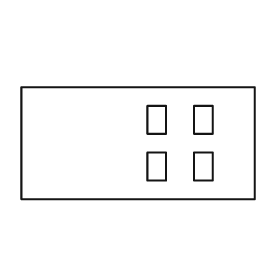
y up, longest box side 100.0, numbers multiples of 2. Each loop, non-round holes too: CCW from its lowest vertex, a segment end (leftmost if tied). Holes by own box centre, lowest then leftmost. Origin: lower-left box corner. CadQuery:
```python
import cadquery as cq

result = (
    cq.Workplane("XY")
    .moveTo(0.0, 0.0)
    .lineTo(100.0, 0.0)
    .lineTo(100.0, 48.0)
    .lineTo(0.0, 48.0)
    .close()
    .moveTo(54.0, 8.0)
    .lineTo(62.0, 8.0)
    .lineTo(62.0, 20.0)
    .lineTo(54.0, 20.0)
    .close()
    .moveTo(74.0, 8.0)
    .lineTo(82.0, 8.0)
    .lineTo(82.0, 20.0)
    .lineTo(74.0, 20.0)
    .close()
    .moveTo(54.0, 28.0)
    .lineTo(62.0, 28.0)
    .lineTo(62.0, 40.0)
    .lineTo(54.0, 40.0)
    .close()
    .moveTo(74.0, 28.0)
    .lineTo(82.0, 28.0)
    .lineTo(82.0, 40.0)
    .lineTo(74.0, 40.0)
    .close()
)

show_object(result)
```